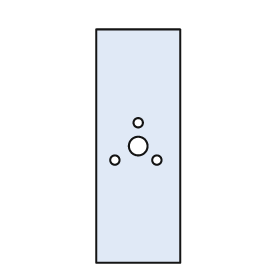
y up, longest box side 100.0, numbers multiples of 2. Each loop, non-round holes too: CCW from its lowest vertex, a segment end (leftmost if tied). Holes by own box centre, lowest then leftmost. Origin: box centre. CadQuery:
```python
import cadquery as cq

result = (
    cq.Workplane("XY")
    .moveTo(-18.0, -50.0)
    .lineTo(18.0, -50.0)
    .lineTo(18.0, 50.0)
    .lineTo(-18.0, 50.0)
    .close()
    .moveTo(-10.0, -6.0)
    .circle(2.0)
    .moveTo(8.0, -6.0)
    .circle(2.0)
    .moveTo(0.0, 0.0)
    .circle(4.0)
    .moveTo(0.0, 10.0)
    .circle(2.0)
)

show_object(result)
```